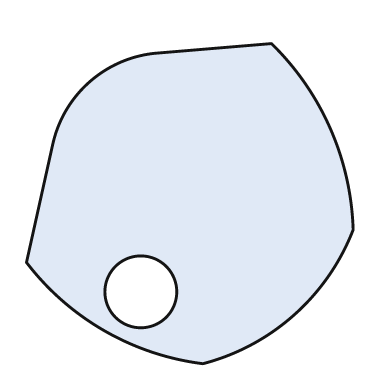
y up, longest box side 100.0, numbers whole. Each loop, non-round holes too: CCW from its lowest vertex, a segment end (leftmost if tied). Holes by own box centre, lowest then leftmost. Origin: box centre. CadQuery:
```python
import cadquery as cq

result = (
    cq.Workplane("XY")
    .moveTo(4.0, -49.0)
    .threePointArc((32.0, -34.0), (50.0, -8.0))
    .threePointArc((43.0, 23.0), (25.0, 49.0))
    .lineTo(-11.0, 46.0)
    .threePointArc((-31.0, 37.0), (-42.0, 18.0))
    .lineTo(-50.0, -18.0)
    .threePointArc((-26.0, -39.0), (4.0, -49.0))
    .close()
    .moveTo(-15.0, -27.0)
    .circle(11.0)
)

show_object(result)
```